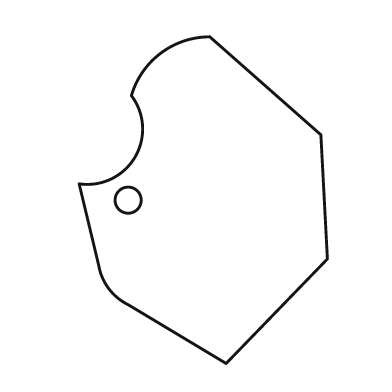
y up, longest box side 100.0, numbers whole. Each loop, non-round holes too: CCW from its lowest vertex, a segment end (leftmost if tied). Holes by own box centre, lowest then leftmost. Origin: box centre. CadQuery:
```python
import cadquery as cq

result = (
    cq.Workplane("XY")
    .moveTo(7.0, -50.0)
    .lineTo(38.0, -18.0)
    .lineTo(36.0, 20.0)
    .lineTo(2.0, 50.0)
    .threePointArc((-13.0, 45.0), (-22.0, 32.0))
    .threePointArc((-21.0, 13.0), (-38.0, 5.0))
    .lineTo(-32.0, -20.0)
    .threePointArc((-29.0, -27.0), (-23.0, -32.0))
    .close()
    .moveTo(-23.0, 0.0)
    .circle(4.0)
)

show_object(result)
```